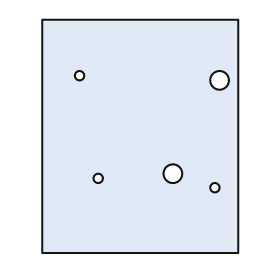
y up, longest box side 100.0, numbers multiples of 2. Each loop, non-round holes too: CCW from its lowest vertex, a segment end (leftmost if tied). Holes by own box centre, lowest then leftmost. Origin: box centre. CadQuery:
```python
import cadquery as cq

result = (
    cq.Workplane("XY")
    .moveTo(-42.0, -50.0)
    .lineTo(42.0, -50.0)
    .lineTo(42.0, 50.0)
    .lineTo(-42.0, 50.0)
    .close()
    .moveTo(32.0, -22.0)
    .circle(2.0)
    .moveTo(-18.0, -18.0)
    .circle(2.0)
    .moveTo(14.0, -16.0)
    .circle(4.0)
    .moveTo(34.0, 24.0)
    .circle(4.0)
    .moveTo(-26.0, 26.0)
    .circle(2.0)
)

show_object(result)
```